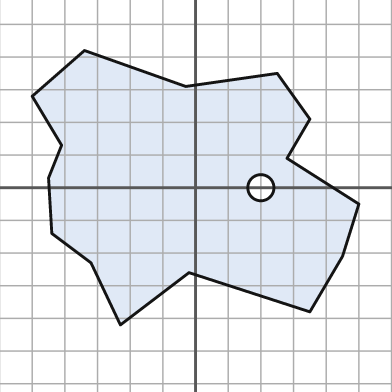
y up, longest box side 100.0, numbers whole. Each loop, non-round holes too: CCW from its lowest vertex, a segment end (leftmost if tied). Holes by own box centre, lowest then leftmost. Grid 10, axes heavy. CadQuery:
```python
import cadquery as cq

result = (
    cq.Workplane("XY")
    .moveTo(-23.0, -42.0)
    .lineTo(-2.0, -26.0)
    .lineTo(35.0, -38.0)
    .lineTo(45.0, -21.0)
    .lineTo(50.0, -5.0)
    .lineTo(28.0, 9.0)
    .lineTo(35.0, 21.0)
    .lineTo(25.0, 35.0)
    .lineTo(-3.0, 31.0)
    .lineTo(-34.0, 42.0)
    .lineTo(-50.0, 28.0)
    .lineTo(-41.0, 13.0)
    .lineTo(-45.0, 3.0)
    .lineTo(-44.0, -14.0)
    .lineTo(-32.0, -23.0)
    .close()
    .moveTo(20.0, 0.0)
    .circle(4.0)
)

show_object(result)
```